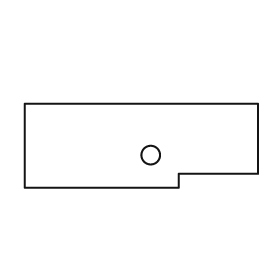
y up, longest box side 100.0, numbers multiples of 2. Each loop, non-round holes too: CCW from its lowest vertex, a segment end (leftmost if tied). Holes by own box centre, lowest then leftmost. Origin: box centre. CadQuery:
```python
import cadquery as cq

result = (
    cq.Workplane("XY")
    .moveTo(-50.0, -18.0)
    .lineTo(16.0, -18.0)
    .lineTo(16.0, -12.0)
    .lineTo(50.0, -12.0)
    .lineTo(50.0, 18.0)
    .lineTo(-50.0, 18.0)
    .close()
    .moveTo(4.0, -4.0)
    .circle(4.0)
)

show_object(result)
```